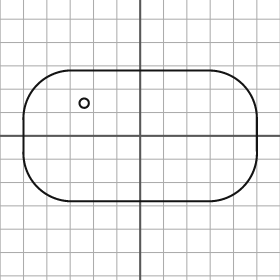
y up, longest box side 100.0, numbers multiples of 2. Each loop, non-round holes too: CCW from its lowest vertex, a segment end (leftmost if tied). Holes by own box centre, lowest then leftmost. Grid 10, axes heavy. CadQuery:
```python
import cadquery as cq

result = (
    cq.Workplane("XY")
    .moveTo(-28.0, -28.0)
    .lineTo(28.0, -28.0)
    .threePointArc((44.0, -22.0), (50.0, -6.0))
    .lineTo(50.0, 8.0)
    .threePointArc((44.0, 22.0), (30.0, 28.0))
    .lineTo(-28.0, 28.0)
    .threePointArc((-44.0, 22.0), (-50.0, 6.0))
    .lineTo(-50.0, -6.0)
    .threePointArc((-44.0, -22.0), (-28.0, -28.0))
    .close()
    .moveTo(-24.0, 14.0)
    .circle(2.0)
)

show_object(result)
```